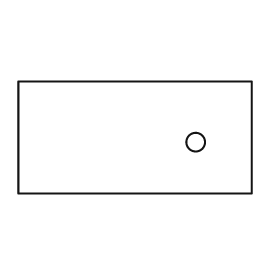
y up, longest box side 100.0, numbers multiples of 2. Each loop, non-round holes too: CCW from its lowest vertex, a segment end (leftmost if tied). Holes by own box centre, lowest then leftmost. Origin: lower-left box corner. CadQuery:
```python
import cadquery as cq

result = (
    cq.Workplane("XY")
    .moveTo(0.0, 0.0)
    .lineTo(100.0, 0.0)
    .lineTo(100.0, 48.0)
    .lineTo(0.0, 48.0)
    .close()
    .moveTo(76.0, 22.0)
    .circle(4.0)
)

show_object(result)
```